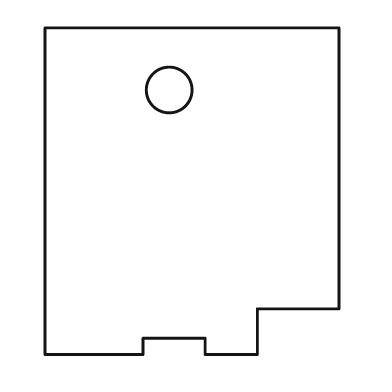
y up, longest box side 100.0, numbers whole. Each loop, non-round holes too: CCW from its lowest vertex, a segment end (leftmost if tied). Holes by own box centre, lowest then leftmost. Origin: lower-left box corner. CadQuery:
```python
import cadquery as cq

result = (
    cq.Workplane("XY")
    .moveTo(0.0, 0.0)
    .lineTo(30.0, 0.0)
    .lineTo(30.0, 5.0)
    .lineTo(49.0, 5.0)
    .lineTo(49.0, 0.0)
    .lineTo(65.0, 0.0)
    .lineTo(65.0, 14.0)
    .lineTo(90.0, 14.0)
    .lineTo(90.0, 100.0)
    .lineTo(0.0, 100.0)
    .close()
    .moveTo(38.0, 81.0)
    .circle(7.0)
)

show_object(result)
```